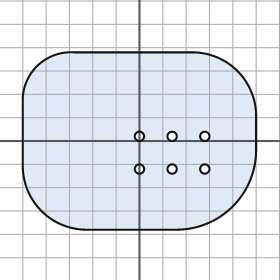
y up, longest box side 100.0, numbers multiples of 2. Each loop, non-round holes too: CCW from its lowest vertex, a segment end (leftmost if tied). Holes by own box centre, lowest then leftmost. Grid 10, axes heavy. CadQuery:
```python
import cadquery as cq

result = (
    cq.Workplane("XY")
    .moveTo(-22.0, -38.0)
    .lineTo(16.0, -38.0)
    .threePointArc((40.0, -28.0), (50.0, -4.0))
    .lineTo(50.0, 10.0)
    .threePointArc((42.0, 30.0), (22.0, 38.0))
    .lineTo(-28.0, 38.0)
    .threePointArc((-44.0, 32.0), (-50.0, 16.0))
    .lineTo(-50.0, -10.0)
    .threePointArc((-42.0, -30.0), (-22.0, -38.0))
    .close()
    .moveTo(0.0, -12.0)
    .circle(2.0)
    .moveTo(14.0, -12.0)
    .circle(2.0)
    .moveTo(28.0, -12.0)
    .circle(2.0)
    .moveTo(0.0, 2.0)
    .circle(2.0)
    .moveTo(14.0, 2.0)
    .circle(2.0)
    .moveTo(28.0, 2.0)
    .circle(2.0)
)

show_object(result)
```